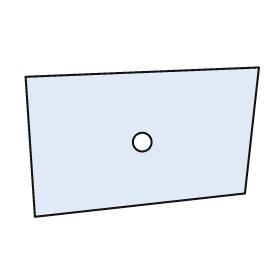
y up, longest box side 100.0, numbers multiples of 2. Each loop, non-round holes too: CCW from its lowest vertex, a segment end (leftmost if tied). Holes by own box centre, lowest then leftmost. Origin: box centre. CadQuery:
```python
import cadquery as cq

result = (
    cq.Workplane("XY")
    .moveTo(-46.0, -32.0)
    .lineTo(44.0, -22.0)
    .lineTo(50.0, 32.0)
    .lineTo(-50.0, 28.0)
    .close()
    .moveTo(0.0, 0.0)
    .circle(4.0)
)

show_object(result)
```